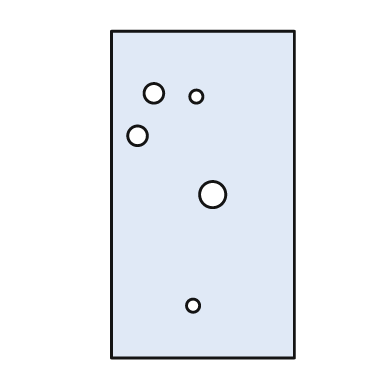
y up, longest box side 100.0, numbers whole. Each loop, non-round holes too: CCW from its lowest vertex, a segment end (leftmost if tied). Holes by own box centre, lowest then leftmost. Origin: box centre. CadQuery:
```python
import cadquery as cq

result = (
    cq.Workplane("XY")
    .moveTo(-28.0, -50.0)
    .lineTo(28.0, -50.0)
    .lineTo(28.0, 50.0)
    .lineTo(-28.0, 50.0)
    .close()
    .moveTo(-3.0, -34.0)
    .circle(2.0)
    .moveTo(3.0, 0.0)
    .circle(4.0)
    .moveTo(-20.0, 18.0)
    .circle(3.0)
    .moveTo(-2.0, 30.0)
    .circle(2.0)
    .moveTo(-15.0, 31.0)
    .circle(3.0)
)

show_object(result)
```